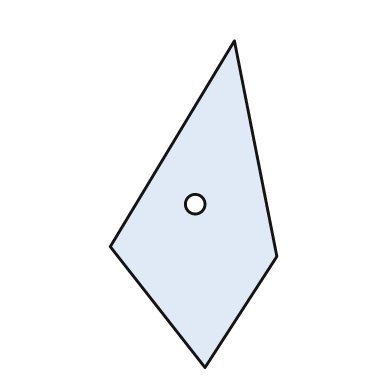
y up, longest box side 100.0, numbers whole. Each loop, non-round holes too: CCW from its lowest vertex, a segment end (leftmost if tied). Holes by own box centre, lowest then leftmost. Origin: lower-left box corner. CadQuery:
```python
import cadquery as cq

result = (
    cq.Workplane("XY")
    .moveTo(29.0, 0.0)
    .lineTo(51.0, 34.0)
    .lineTo(38.0, 100.0)
    .lineTo(0.0, 37.0)
    .close()
    .moveTo(26.0, 50.0)
    .circle(3.0)
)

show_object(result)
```